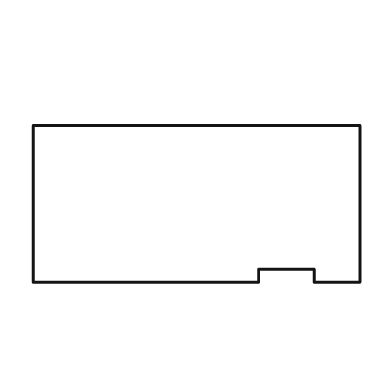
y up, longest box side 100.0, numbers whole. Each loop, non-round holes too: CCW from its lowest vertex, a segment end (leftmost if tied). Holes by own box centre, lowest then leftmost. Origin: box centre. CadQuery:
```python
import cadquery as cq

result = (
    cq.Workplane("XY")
    .moveTo(-50.0, -24.0)
    .lineTo(19.0, -24.0)
    .lineTo(19.0, -20.0)
    .lineTo(36.0, -20.0)
    .lineTo(36.0, -24.0)
    .lineTo(50.0, -24.0)
    .lineTo(50.0, 24.0)
    .lineTo(-50.0, 24.0)
    .close()
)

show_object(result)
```